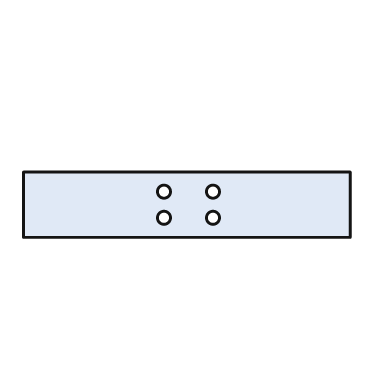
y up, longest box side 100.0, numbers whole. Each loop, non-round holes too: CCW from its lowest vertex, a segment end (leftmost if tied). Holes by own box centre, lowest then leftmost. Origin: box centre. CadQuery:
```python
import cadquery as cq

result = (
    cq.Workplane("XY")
    .moveTo(-50.0, -10.0)
    .lineTo(50.0, -10.0)
    .lineTo(50.0, 10.0)
    .lineTo(-50.0, 10.0)
    .close()
    .moveTo(-7.0, -4.0)
    .circle(2.0)
    .moveTo(8.0, -4.0)
    .circle(2.0)
    .moveTo(-7.0, 4.0)
    .circle(2.0)
    .moveTo(8.0, 4.0)
    .circle(2.0)
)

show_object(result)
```